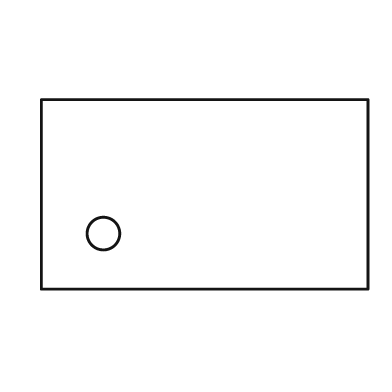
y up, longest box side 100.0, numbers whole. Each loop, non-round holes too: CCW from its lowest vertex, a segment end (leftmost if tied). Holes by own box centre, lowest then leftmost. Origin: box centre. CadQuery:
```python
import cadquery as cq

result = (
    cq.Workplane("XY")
    .moveTo(-50.0, -29.0)
    .lineTo(50.0, -29.0)
    .lineTo(50.0, 29.0)
    .lineTo(-50.0, 29.0)
    .close()
    .moveTo(-31.0, -12.0)
    .circle(5.0)
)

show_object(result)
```